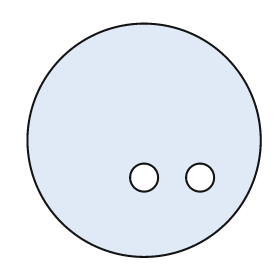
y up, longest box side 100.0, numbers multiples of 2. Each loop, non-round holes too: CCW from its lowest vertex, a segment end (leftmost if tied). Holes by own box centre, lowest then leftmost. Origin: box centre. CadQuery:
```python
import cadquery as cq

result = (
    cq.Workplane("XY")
    .moveTo(0.0, 0.0)
    .circle(50.0)
    .moveTo(0.0, -16.0)
    .circle(6.0)
    .moveTo(24.0, -16.0)
    .circle(6.0)
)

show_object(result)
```